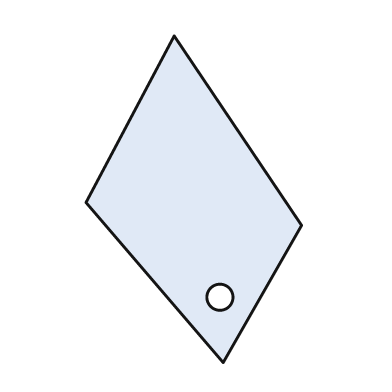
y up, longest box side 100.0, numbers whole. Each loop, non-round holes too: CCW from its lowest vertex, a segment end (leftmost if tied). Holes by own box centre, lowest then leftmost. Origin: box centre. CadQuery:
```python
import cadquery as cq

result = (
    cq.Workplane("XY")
    .moveTo(9.0, -50.0)
    .lineTo(33.0, -8.0)
    .lineTo(-6.0, 50.0)
    .lineTo(-33.0, -1.0)
    .close()
    .moveTo(8.0, -30.0)
    .circle(4.0)
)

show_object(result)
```